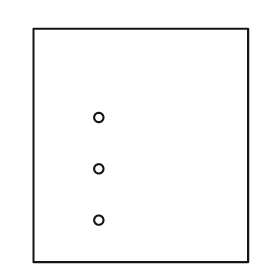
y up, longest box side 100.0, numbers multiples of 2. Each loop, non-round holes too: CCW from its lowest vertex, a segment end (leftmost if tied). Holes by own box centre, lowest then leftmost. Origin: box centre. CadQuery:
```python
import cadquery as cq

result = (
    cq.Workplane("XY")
    .moveTo(-46.0, -50.0)
    .lineTo(46.0, -50.0)
    .lineTo(46.0, 50.0)
    .lineTo(-46.0, 50.0)
    .close()
    .moveTo(-18.0, -32.0)
    .circle(2.0)
    .moveTo(-18.0, -10.0)
    .circle(2.0)
    .moveTo(-18.0, 12.0)
    .circle(2.0)
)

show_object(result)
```